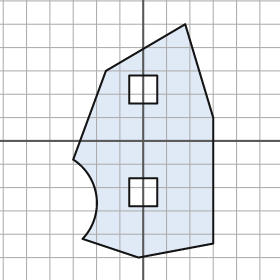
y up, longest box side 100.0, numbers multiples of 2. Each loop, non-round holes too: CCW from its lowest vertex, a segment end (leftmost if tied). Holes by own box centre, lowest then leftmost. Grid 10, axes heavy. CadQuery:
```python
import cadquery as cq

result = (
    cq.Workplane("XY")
    .moveTo(-2.0, -50.0)
    .lineTo(30.0, -44.0)
    .lineTo(30.0, 10.0)
    .lineTo(18.0, 50.0)
    .lineTo(-16.0, 30.0)
    .lineTo(-30.0, -8.0)
    .threePointArc((-20.0, -24.0), (-26.0, -42.0))
    .close()
    .moveTo(-6.0, -28.0)
    .lineTo(6.0, -28.0)
    .lineTo(6.0, -16.0)
    .lineTo(-6.0, -16.0)
    .close()
    .moveTo(-6.0, 16.0)
    .lineTo(6.0, 16.0)
    .lineTo(6.0, 28.0)
    .lineTo(-6.0, 28.0)
    .close()
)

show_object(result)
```